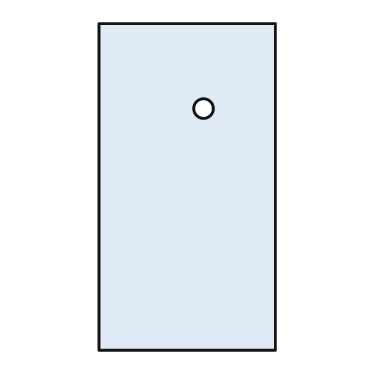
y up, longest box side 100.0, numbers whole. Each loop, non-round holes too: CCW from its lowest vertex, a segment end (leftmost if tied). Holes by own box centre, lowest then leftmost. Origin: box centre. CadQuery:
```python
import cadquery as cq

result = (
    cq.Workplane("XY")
    .moveTo(-27.0, -50.0)
    .lineTo(27.0, -50.0)
    .lineTo(27.0, 50.0)
    .lineTo(-27.0, 50.0)
    .close()
    .moveTo(5.0, 24.0)
    .circle(3.0)
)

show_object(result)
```